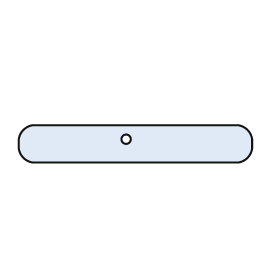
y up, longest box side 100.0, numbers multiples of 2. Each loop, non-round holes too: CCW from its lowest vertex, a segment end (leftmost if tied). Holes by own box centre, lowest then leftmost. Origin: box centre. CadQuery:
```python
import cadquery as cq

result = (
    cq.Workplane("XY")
    .moveTo(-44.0, -8.0)
    .lineTo(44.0, -8.0)
    .threePointArc((48.0, -6.0), (50.0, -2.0))
    .lineTo(50.0, 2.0)
    .threePointArc((48.0, 6.0), (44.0, 8.0))
    .lineTo(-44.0, 8.0)
    .threePointArc((-48.0, 6.0), (-50.0, 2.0))
    .lineTo(-50.0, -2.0)
    .threePointArc((-48.0, -6.0), (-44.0, -8.0))
    .close()
    .moveTo(-4.0, 2.0)
    .circle(2.0)
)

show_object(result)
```